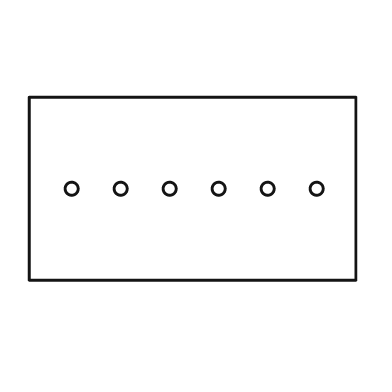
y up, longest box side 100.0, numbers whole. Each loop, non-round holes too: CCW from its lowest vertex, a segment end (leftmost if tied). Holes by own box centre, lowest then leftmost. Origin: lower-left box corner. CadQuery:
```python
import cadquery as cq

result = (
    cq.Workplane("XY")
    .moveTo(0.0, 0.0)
    .lineTo(100.0, 0.0)
    .lineTo(100.0, 56.0)
    .lineTo(0.0, 56.0)
    .close()
    .moveTo(13.0, 28.0)
    .circle(2.0)
    .moveTo(28.0, 28.0)
    .circle(2.0)
    .moveTo(43.0, 28.0)
    .circle(2.0)
    .moveTo(58.0, 28.0)
    .circle(2.0)
    .moveTo(73.0, 28.0)
    .circle(2.0)
    .moveTo(88.0, 28.0)
    .circle(2.0)
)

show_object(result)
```